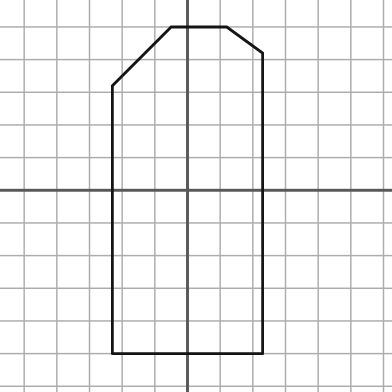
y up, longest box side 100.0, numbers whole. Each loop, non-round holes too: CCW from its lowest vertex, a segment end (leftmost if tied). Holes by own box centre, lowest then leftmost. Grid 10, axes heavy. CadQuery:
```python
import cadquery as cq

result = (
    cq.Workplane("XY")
    .moveTo(-23.0, -50.0)
    .lineTo(23.0, -50.0)
    .lineTo(23.0, 42.0)
    .lineTo(12.0, 50.0)
    .lineTo(-5.0, 50.0)
    .lineTo(-23.0, 32.0)
    .close()
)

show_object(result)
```